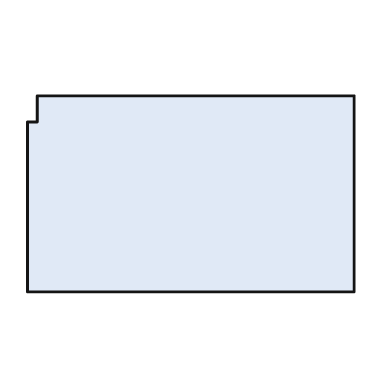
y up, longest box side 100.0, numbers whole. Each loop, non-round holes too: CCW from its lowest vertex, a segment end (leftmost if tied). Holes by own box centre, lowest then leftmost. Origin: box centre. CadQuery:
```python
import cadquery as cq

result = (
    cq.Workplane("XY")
    .moveTo(-50.0, -30.0)
    .lineTo(50.0, -30.0)
    .lineTo(50.0, 30.0)
    .lineTo(-47.0, 30.0)
    .lineTo(-47.0, 22.0)
    .lineTo(-50.0, 22.0)
    .close()
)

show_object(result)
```